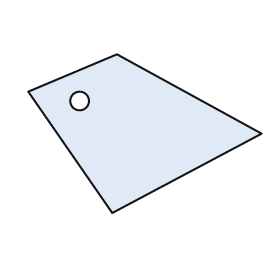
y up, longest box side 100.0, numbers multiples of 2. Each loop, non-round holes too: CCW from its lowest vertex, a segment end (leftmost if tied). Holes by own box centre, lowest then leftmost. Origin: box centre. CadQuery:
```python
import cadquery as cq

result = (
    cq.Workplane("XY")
    .moveTo(-14.0, -34.0)
    .lineTo(50.0, 0.0)
    .lineTo(-12.0, 34.0)
    .lineTo(-50.0, 18.0)
    .close()
    .moveTo(-28.0, 14.0)
    .circle(4.0)
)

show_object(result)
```